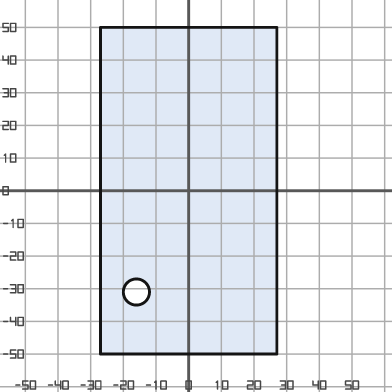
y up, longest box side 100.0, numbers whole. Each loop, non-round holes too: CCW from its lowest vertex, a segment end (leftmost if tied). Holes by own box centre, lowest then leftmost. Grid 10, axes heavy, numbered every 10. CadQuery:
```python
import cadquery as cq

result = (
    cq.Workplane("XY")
    .moveTo(-27.0, -50.0)
    .lineTo(27.0, -50.0)
    .lineTo(27.0, 50.0)
    .lineTo(-27.0, 50.0)
    .close()
    .moveTo(-16.0, -31.0)
    .circle(4.0)
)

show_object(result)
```